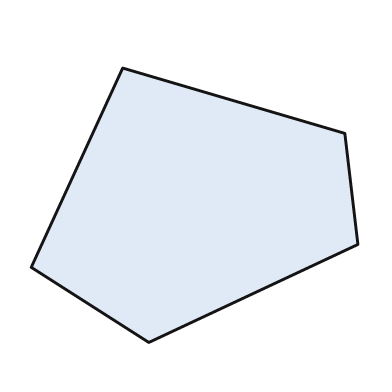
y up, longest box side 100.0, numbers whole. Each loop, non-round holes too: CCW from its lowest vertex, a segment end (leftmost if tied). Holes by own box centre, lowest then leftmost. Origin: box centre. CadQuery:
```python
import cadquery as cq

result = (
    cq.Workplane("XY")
    .moveTo(-14.0, -42.0)
    .lineTo(50.0, -12.0)
    .lineTo(46.0, 22.0)
    .lineTo(-22.0, 42.0)
    .lineTo(-50.0, -19.0)
    .close()
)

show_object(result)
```